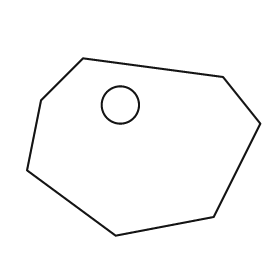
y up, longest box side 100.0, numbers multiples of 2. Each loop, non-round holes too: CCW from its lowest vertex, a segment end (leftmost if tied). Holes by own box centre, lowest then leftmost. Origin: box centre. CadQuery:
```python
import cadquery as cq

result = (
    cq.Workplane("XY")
    .moveTo(-12.0, -38.0)
    .lineTo(30.0, -30.0)
    .lineTo(50.0, 10.0)
    .lineTo(34.0, 30.0)
    .lineTo(-26.0, 38.0)
    .lineTo(-44.0, 20.0)
    .lineTo(-50.0, -10.0)
    .close()
    .moveTo(-10.0, 18.0)
    .circle(8.0)
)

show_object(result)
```